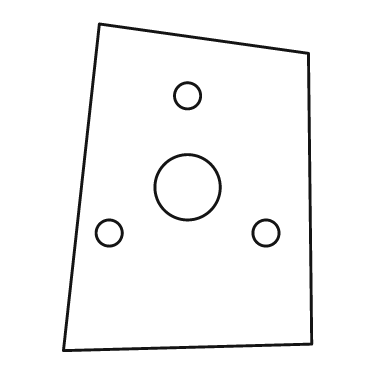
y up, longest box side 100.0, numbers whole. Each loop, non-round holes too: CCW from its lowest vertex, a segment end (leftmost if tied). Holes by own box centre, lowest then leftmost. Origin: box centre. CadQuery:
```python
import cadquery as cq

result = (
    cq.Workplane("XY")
    .moveTo(-38.0, -50.0)
    .lineTo(38.0, -48.0)
    .lineTo(37.0, 41.0)
    .lineTo(-27.0, 50.0)
    .close()
    .moveTo(-24.0, -14.0)
    .circle(4.0)
    .moveTo(24.0, -14.0)
    .circle(4.0)
    .moveTo(0.0, 0.0)
    .circle(10.0)
    .moveTo(0.0, 28.0)
    .circle(4.0)
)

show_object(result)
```